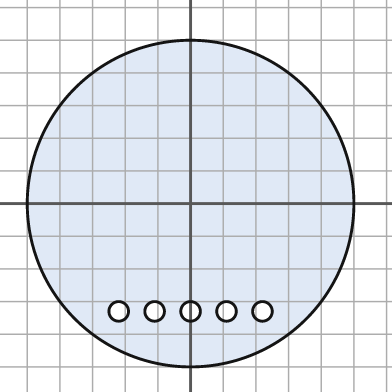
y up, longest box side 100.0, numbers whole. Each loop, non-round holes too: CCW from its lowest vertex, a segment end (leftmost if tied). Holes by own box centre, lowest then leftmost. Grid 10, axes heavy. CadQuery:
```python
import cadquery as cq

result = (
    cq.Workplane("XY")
    .moveTo(0.0, 0.0)
    .circle(50.0)
    .moveTo(-22.0, -33.0)
    .circle(3.0)
    .moveTo(-11.0, -33.0)
    .circle(3.0)
    .moveTo(0.0, -33.0)
    .circle(3.0)
    .moveTo(11.0, -33.0)
    .circle(3.0)
    .moveTo(22.0, -33.0)
    .circle(3.0)
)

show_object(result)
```